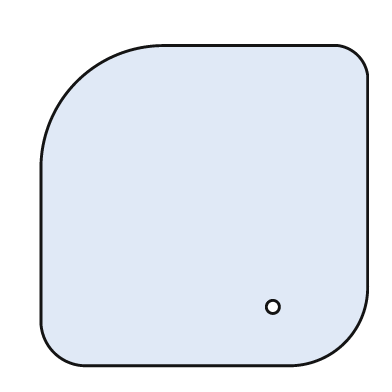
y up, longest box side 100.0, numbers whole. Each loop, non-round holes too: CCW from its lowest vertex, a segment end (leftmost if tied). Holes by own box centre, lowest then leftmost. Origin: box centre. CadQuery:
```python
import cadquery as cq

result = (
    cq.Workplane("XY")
    .moveTo(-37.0, -49.0)
    .lineTo(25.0, -49.0)
    .threePointArc((43.0, -42.0), (50.0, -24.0))
    .lineTo(50.0, 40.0)
    .threePointArc((47.0, 46.0), (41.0, 49.0))
    .lineTo(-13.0, 49.0)
    .threePointArc((-39.0, 38.0), (-50.0, 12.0))
    .lineTo(-50.0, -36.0)
    .threePointArc((-46.0, -45.0), (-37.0, -49.0))
    .close()
    .moveTo(21.0, -31.0)
    .circle(2.0)
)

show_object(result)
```